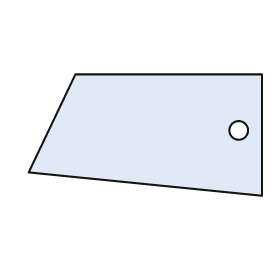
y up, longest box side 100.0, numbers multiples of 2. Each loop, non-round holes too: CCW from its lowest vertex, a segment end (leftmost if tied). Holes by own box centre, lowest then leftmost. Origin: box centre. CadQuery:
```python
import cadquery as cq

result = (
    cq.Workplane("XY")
    .moveTo(50.0, -26.0)
    .lineTo(50.0, 26.0)
    .lineTo(-30.0, 26.0)
    .lineTo(-50.0, -16.0)
    .close()
    .moveTo(40.0, 2.0)
    .circle(4.0)
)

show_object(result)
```